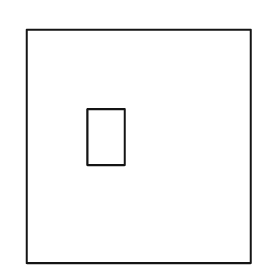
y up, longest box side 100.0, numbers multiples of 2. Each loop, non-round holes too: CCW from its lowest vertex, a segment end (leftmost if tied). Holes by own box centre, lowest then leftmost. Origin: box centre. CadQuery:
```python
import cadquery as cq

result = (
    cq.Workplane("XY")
    .moveTo(-48.0, -50.0)
    .lineTo(48.0, -50.0)
    .lineTo(48.0, 50.0)
    .lineTo(-48.0, 50.0)
    .close()
    .moveTo(-22.0, -8.0)
    .lineTo(-6.0, -8.0)
    .lineTo(-6.0, 16.0)
    .lineTo(-22.0, 16.0)
    .close()
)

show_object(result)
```